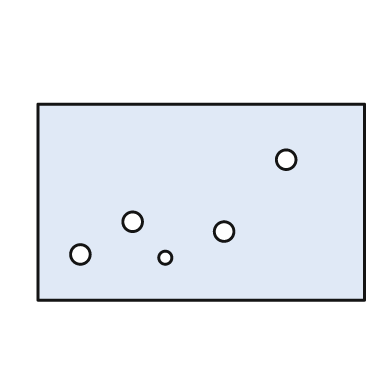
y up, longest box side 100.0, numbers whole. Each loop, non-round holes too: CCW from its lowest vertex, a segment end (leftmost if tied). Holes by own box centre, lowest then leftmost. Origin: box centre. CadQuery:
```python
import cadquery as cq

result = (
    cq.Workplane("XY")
    .moveTo(-50.0, -30.0)
    .lineTo(50.0, -30.0)
    .lineTo(50.0, 30.0)
    .lineTo(-50.0, 30.0)
    .close()
    .moveTo(-11.0, -17.0)
    .circle(2.0)
    .moveTo(-37.0, -16.0)
    .circle(3.0)
    .moveTo(7.0, -9.0)
    .circle(3.0)
    .moveTo(-21.0, -6.0)
    .circle(3.0)
    .moveTo(26.0, 13.0)
    .circle(3.0)
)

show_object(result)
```